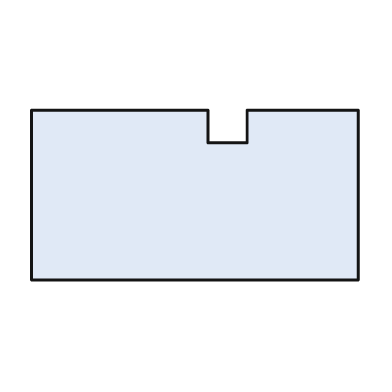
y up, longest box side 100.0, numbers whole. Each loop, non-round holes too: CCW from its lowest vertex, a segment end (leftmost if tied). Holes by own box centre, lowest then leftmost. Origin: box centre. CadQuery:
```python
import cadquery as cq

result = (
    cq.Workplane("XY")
    .moveTo(-50.0, -26.0)
    .lineTo(50.0, -26.0)
    .lineTo(50.0, 26.0)
    .lineTo(16.0, 26.0)
    .lineTo(16.0, 16.0)
    .lineTo(4.0, 16.0)
    .lineTo(4.0, 26.0)
    .lineTo(-50.0, 26.0)
    .close()
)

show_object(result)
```